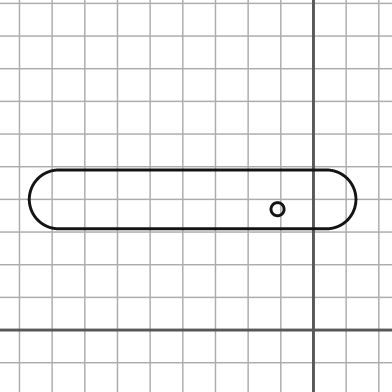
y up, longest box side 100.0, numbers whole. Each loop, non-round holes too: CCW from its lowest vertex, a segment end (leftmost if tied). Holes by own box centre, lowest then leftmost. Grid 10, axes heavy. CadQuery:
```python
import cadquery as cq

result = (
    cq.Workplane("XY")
    .moveTo(-78.0, 31.0)
    .lineTo(4.0, 31.0)
    .threePointArc((13.0, 40.0), (4.0, 49.0))
    .lineTo(-78.0, 49.0)
    .threePointArc((-87.0, 40.0), (-78.0, 31.0))
    .close()
    .moveTo(-11.0, 37.0)
    .circle(2.0)
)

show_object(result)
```